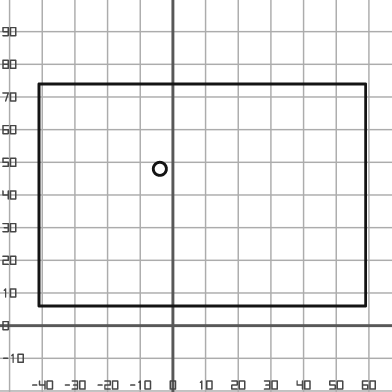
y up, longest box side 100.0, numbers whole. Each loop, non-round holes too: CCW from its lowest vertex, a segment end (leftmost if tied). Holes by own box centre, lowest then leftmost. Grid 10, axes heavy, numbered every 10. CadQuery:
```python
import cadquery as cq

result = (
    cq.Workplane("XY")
    .moveTo(-41.0, 6.0)
    .lineTo(59.0, 6.0)
    .lineTo(59.0, 74.0)
    .lineTo(-41.0, 74.0)
    .close()
    .moveTo(-4.0, 48.0)
    .circle(2.0)
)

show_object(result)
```